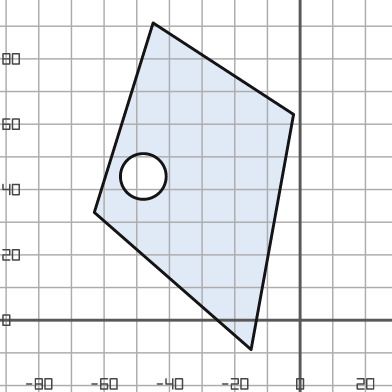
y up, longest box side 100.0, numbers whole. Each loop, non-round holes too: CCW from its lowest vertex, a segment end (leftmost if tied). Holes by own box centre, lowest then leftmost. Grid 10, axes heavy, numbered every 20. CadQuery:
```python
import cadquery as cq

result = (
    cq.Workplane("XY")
    .moveTo(-15.0, -9.0)
    .lineTo(-2.0, 63.0)
    .lineTo(-45.0, 91.0)
    .lineTo(-63.0, 33.0)
    .close()
    .moveTo(-48.0, 44.0)
    .circle(7.0)
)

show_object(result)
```